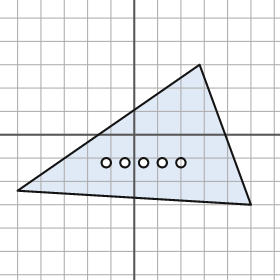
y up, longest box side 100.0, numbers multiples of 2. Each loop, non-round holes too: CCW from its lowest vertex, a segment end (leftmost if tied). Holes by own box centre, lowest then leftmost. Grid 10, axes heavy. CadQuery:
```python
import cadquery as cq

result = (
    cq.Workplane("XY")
    .moveTo(50.0, -30.0)
    .lineTo(28.0, 30.0)
    .lineTo(-50.0, -24.0)
    .close()
    .moveTo(-12.0, -12.0)
    .circle(2.0)
    .moveTo(-4.0, -12.0)
    .circle(2.0)
    .moveTo(4.0, -12.0)
    .circle(2.0)
    .moveTo(12.0, -12.0)
    .circle(2.0)
    .moveTo(20.0, -12.0)
    .circle(2.0)
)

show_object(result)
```